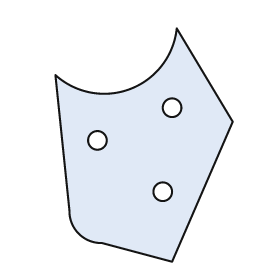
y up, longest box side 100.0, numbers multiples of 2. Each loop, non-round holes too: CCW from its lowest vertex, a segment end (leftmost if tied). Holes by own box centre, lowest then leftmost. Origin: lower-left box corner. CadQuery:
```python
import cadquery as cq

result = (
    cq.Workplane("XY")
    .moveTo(50.0, 0.0)
    .lineTo(76.0, 60.0)
    .lineTo(52.0, 100.0)
    .threePointArc((32.0, 74.0), (0.0, 80.0))
    .lineTo(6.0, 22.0)
    .threePointArc((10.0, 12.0), (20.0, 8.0))
    .close()
    .moveTo(46.0, 30.0)
    .circle(4.0)
    .moveTo(18.0, 52.0)
    .circle(4.0)
    .moveTo(50.0, 66.0)
    .circle(4.0)
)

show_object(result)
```